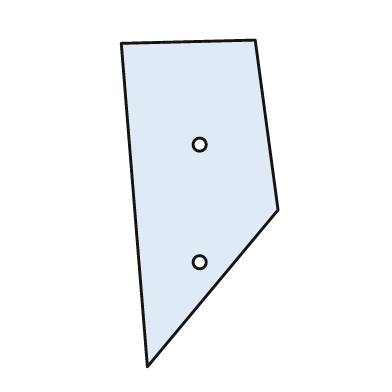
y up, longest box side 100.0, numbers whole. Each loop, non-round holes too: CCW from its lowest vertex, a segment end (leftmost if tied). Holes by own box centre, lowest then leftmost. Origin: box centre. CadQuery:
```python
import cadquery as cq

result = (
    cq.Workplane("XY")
    .moveTo(-16.0, -50.0)
    .lineTo(24.0, -2.0)
    .lineTo(17.0, 50.0)
    .lineTo(-24.0, 49.0)
    .close()
    .moveTo(0.0, -18.0)
    .circle(2.0)
    .moveTo(0.0, 18.0)
    .circle(2.0)
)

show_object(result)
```